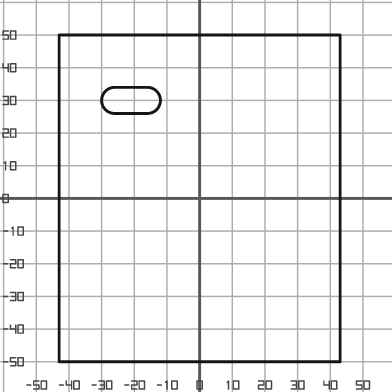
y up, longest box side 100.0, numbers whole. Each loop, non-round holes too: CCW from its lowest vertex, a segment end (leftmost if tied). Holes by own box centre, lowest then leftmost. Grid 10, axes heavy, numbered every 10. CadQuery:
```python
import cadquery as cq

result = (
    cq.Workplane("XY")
    .moveTo(-43.0, -50.0)
    .lineTo(43.0, -50.0)
    .lineTo(43.0, 50.0)
    .lineTo(-43.0, 50.0)
    .close()
    .moveTo(-26.0, 26.0)
    .lineTo(-16.0, 26.0)
    .threePointArc((-12.0, 30.0), (-16.0, 34.0))
    .lineTo(-26.0, 34.0)
    .threePointArc((-30.0, 30.0), (-26.0, 26.0))
    .close()
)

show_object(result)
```